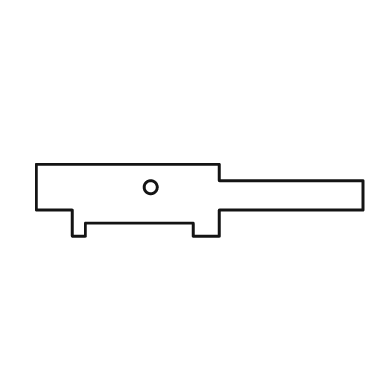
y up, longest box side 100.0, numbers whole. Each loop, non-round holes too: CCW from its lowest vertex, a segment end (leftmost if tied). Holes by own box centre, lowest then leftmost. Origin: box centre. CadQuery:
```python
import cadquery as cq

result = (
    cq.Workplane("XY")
    .moveTo(-39.0, -11.0)
    .lineTo(-35.0, -11.0)
    .lineTo(-35.0, -7.0)
    .lineTo(-2.0, -7.0)
    .lineTo(-2.0, -11.0)
    .lineTo(6.0, -11.0)
    .lineTo(6.0, -3.0)
    .lineTo(50.0, -3.0)
    .lineTo(50.0, 6.0)
    .lineTo(6.0, 6.0)
    .lineTo(6.0, 11.0)
    .lineTo(-50.0, 11.0)
    .lineTo(-50.0, -3.0)
    .lineTo(-39.0, -3.0)
    .close()
    .moveTo(-15.0, 4.0)
    .circle(2.0)
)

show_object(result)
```